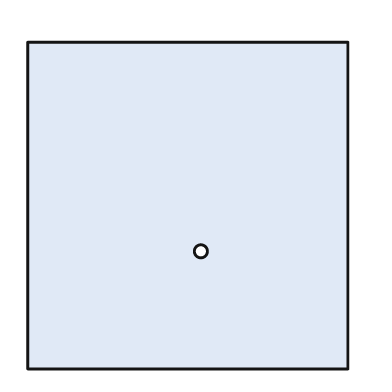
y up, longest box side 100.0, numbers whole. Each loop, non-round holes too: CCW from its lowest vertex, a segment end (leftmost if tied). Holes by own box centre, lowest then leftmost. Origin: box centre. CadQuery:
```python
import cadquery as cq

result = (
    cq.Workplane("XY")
    .moveTo(-49.0, -50.0)
    .lineTo(49.0, -50.0)
    .lineTo(49.0, 50.0)
    .lineTo(-49.0, 50.0)
    .close()
    .moveTo(4.0, -14.0)
    .circle(2.0)
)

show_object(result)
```